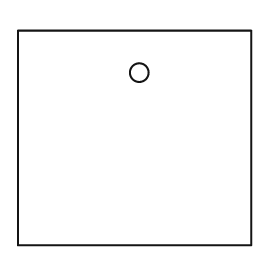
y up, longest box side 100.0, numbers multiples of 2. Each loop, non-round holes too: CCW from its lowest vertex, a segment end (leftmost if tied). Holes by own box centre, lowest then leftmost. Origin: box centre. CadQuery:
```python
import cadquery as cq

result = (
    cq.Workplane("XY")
    .moveTo(-50.0, -46.0)
    .lineTo(50.0, -46.0)
    .lineTo(50.0, 46.0)
    .lineTo(-50.0, 46.0)
    .close()
    .moveTo(2.0, 28.0)
    .circle(4.0)
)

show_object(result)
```